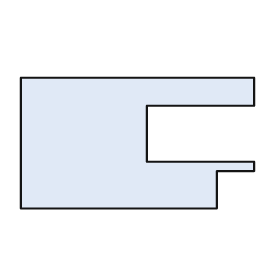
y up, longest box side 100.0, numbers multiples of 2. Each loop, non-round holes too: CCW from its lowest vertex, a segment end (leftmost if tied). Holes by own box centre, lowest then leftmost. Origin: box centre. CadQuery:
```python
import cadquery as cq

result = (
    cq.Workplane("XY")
    .moveTo(-50.0, -28.0)
    .lineTo(34.0, -28.0)
    .lineTo(34.0, -12.0)
    .lineTo(50.0, -12.0)
    .lineTo(50.0, -8.0)
    .lineTo(4.0, -8.0)
    .lineTo(4.0, 16.0)
    .lineTo(50.0, 16.0)
    .lineTo(50.0, 28.0)
    .lineTo(-50.0, 28.0)
    .close()
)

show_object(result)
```